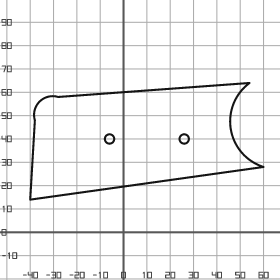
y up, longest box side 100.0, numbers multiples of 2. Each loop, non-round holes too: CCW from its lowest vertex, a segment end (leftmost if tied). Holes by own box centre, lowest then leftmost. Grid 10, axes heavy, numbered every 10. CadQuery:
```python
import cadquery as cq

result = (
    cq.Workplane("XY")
    .moveTo(-40.0, 14.0)
    .lineTo(60.0, 28.0)
    .threePointArc((46.0, 44.0), (54.0, 64.0))
    .lineTo(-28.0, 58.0)
    .threePointArc((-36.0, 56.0), (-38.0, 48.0))
    .close()
    .moveTo(-6.0, 40.0)
    .circle(2.0)
    .moveTo(26.0, 40.0)
    .circle(2.0)
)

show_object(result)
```